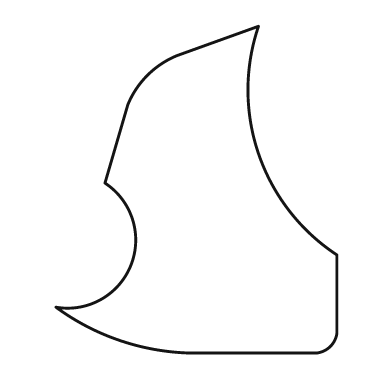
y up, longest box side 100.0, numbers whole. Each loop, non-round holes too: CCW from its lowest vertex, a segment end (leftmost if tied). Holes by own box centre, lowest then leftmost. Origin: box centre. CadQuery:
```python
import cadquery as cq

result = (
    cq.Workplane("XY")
    .moveTo(-3.0, -50.0)
    .lineTo(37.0, -50.0)
    .threePointArc((41.0, -48.0), (43.0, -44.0))
    .lineTo(43.0, -20.0)
    .threePointArc((19.0, 11.0), (19.0, 50.0))
    .lineTo(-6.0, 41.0)
    .threePointArc((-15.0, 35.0), (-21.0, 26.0))
    .lineTo(-28.0, 2.0)
    .threePointArc((-20.0, -23.0), (-43.0, -36.0))
    .threePointArc((-24.0, -46.0), (-3.0, -50.0))
    .close()
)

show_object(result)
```